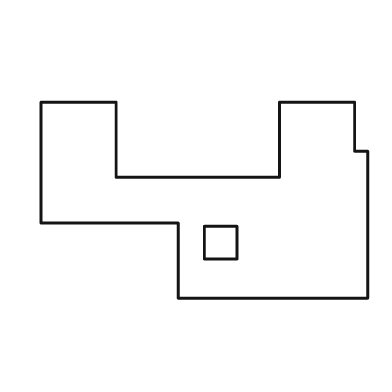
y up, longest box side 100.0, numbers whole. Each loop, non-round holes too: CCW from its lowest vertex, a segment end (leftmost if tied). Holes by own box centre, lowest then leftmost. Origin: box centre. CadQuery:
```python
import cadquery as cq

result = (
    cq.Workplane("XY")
    .moveTo(-8.0, -30.0)
    .lineTo(50.0, -30.0)
    .lineTo(50.0, 15.0)
    .lineTo(46.0, 15.0)
    .lineTo(46.0, 30.0)
    .lineTo(23.0, 30.0)
    .lineTo(23.0, 7.0)
    .lineTo(-27.0, 7.0)
    .lineTo(-27.0, 30.0)
    .lineTo(-50.0, 30.0)
    .lineTo(-50.0, -7.0)
    .lineTo(-8.0, -7.0)
    .close()
    .moveTo(0.0, -18.0)
    .lineTo(10.0, -18.0)
    .lineTo(10.0, -8.0)
    .lineTo(0.0, -8.0)
    .close()
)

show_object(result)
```